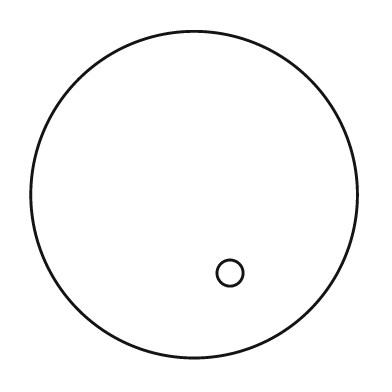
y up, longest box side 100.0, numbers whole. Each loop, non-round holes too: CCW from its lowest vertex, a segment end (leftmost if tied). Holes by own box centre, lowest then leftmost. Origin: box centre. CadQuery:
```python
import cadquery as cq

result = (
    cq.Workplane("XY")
    .moveTo(0.0, 0.0)
    .circle(50.0)
    .moveTo(11.0, -24.0)
    .circle(4.0)
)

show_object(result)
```